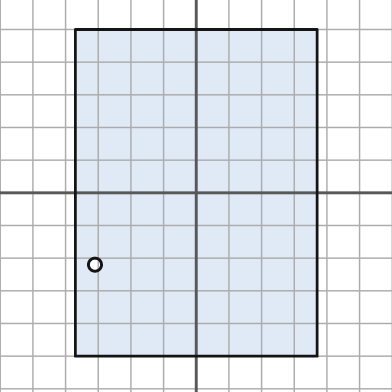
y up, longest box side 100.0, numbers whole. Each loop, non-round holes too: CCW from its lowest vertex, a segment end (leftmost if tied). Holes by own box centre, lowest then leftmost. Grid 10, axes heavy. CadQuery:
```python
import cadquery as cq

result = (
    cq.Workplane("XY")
    .moveTo(-37.0, -50.0)
    .lineTo(37.0, -50.0)
    .lineTo(37.0, 50.0)
    .lineTo(-37.0, 50.0)
    .close()
    .moveTo(-31.0, -22.0)
    .circle(2.0)
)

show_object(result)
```